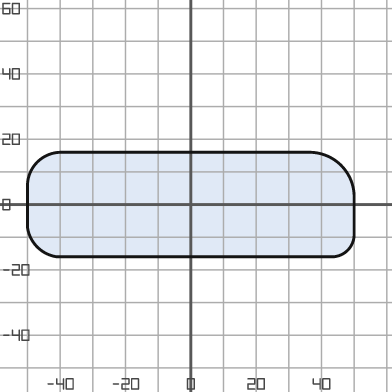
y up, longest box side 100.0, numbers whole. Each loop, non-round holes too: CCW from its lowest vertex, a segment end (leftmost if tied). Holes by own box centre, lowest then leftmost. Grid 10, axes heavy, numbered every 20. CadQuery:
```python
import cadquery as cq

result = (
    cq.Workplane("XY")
    .moveTo(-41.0, -16.0)
    .lineTo(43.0, -16.0)
    .threePointArc((48.0, -14.0), (50.0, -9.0))
    .lineTo(50.0, 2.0)
    .threePointArc((46.0, 12.0), (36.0, 16.0))
    .lineTo(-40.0, 16.0)
    .threePointArc((-47.0, 13.0), (-50.0, 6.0))
    .lineTo(-50.0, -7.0)
    .threePointArc((-47.0, -13.0), (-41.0, -16.0))
    .close()
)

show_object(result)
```